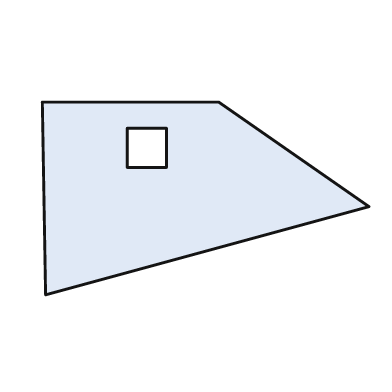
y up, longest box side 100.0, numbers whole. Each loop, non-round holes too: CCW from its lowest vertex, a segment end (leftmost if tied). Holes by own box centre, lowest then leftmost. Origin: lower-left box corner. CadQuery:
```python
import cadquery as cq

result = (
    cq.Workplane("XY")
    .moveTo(1.0, 0.0)
    .lineTo(100.0, 27.0)
    .lineTo(54.0, 59.0)
    .lineTo(0.0, 59.0)
    .close()
    .moveTo(26.0, 39.0)
    .lineTo(38.0, 39.0)
    .lineTo(38.0, 51.0)
    .lineTo(26.0, 51.0)
    .close()
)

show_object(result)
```